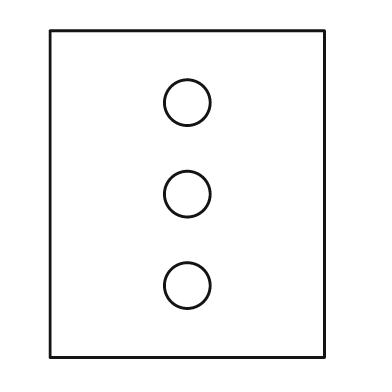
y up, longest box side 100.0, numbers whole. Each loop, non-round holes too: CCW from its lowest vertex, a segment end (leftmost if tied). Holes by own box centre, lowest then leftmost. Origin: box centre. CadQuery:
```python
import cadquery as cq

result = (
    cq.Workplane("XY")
    .moveTo(-42.0, -50.0)
    .lineTo(42.0, -50.0)
    .lineTo(42.0, 50.0)
    .lineTo(-42.0, 50.0)
    .close()
    .moveTo(0.0, -28.0)
    .circle(7.0)
    .moveTo(0.0, 0.0)
    .circle(7.0)
    .moveTo(0.0, 28.0)
    .circle(7.0)
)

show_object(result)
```